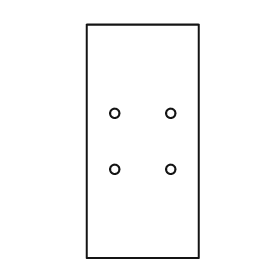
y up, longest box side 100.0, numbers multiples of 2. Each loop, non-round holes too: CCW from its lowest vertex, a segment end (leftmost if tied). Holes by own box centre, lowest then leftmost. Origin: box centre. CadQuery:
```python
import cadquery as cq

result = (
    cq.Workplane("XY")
    .moveTo(-24.0, -50.0)
    .lineTo(24.0, -50.0)
    .lineTo(24.0, 50.0)
    .lineTo(-24.0, 50.0)
    .close()
    .moveTo(-12.0, -12.0)
    .circle(2.0)
    .moveTo(12.0, -12.0)
    .circle(2.0)
    .moveTo(-12.0, 12.0)
    .circle(2.0)
    .moveTo(12.0, 12.0)
    .circle(2.0)
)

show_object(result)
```